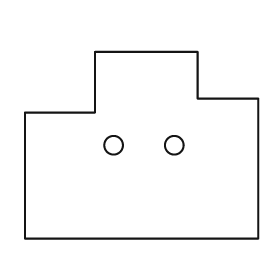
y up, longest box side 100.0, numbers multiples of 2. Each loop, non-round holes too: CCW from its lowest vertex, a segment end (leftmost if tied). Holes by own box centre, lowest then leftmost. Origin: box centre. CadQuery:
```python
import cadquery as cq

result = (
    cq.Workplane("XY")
    .moveTo(-50.0, -40.0)
    .lineTo(50.0, -40.0)
    .lineTo(50.0, 20.0)
    .lineTo(24.0, 20.0)
    .lineTo(24.0, 40.0)
    .lineTo(-20.0, 40.0)
    .lineTo(-20.0, 14.0)
    .lineTo(-50.0, 14.0)
    .close()
    .moveTo(-12.0, 0.0)
    .circle(4.0)
    .moveTo(14.0, 0.0)
    .circle(4.0)
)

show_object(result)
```